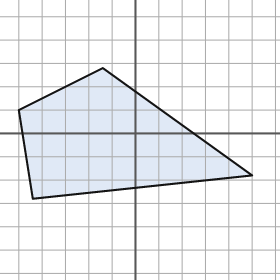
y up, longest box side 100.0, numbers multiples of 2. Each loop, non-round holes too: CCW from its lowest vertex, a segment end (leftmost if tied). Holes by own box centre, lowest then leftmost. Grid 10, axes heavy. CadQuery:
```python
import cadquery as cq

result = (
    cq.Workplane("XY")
    .moveTo(-44.0, -28.0)
    .lineTo(50.0, -18.0)
    .lineTo(-14.0, 28.0)
    .lineTo(-50.0, 10.0)
    .close()
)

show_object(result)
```